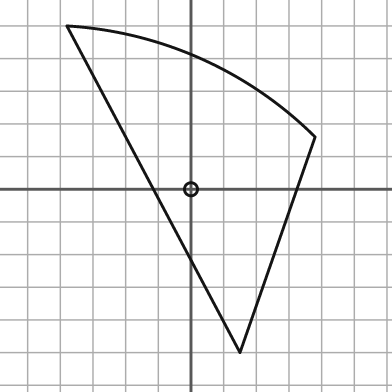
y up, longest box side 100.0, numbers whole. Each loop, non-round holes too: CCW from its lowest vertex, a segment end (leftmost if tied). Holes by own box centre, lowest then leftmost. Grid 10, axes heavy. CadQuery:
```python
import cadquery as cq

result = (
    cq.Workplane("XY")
    .moveTo(15.0, -50.0)
    .lineTo(38.0, 16.0)
    .threePointArc((3.0, 40.0), (-38.0, 50.0))
    .close()
    .moveTo(0.0, 0.0)
    .circle(2.0)
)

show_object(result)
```